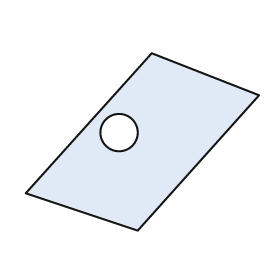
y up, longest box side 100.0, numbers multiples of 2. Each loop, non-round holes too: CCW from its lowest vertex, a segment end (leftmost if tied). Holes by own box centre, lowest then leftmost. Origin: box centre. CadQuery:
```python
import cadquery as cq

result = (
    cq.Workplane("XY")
    .moveTo(-2.0, -38.0)
    .lineTo(50.0, 20.0)
    .lineTo(4.0, 38.0)
    .lineTo(-50.0, -22.0)
    .close()
    .moveTo(-10.0, 4.0)
    .circle(8.0)
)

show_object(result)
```